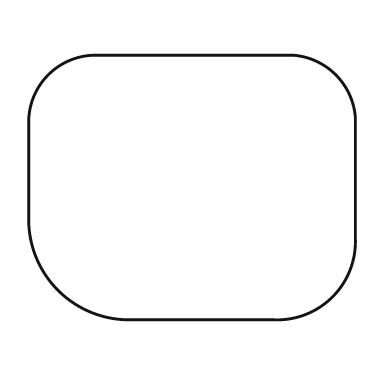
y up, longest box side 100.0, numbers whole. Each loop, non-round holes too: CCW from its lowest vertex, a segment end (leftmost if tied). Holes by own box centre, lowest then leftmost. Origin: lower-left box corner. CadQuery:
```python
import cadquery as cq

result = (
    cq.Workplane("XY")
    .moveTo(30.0, 0.0)
    .lineTo(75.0, 0.0)
    .threePointArc((93.0, 7.0), (100.0, 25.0))
    .lineTo(100.0, 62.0)
    .threePointArc((94.0, 75.0), (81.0, 81.0))
    .lineTo(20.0, 81.0)
    .threePointArc((6.0, 75.0), (0.0, 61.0))
    .lineTo(0.0, 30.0)
    .threePointArc((9.0, 9.0), (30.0, 0.0))
    .close()
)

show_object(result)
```